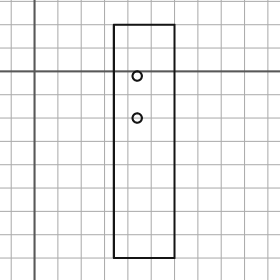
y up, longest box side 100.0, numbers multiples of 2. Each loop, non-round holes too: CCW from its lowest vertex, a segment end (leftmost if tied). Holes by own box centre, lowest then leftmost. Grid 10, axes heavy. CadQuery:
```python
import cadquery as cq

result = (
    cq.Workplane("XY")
    .moveTo(34.0, -80.0)
    .lineTo(60.0, -80.0)
    .lineTo(60.0, 20.0)
    .lineTo(34.0, 20.0)
    .close()
    .moveTo(44.0, -20.0)
    .circle(2.0)
    .moveTo(44.0, -2.0)
    .circle(2.0)
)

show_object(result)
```